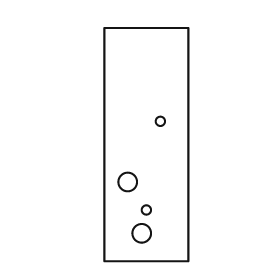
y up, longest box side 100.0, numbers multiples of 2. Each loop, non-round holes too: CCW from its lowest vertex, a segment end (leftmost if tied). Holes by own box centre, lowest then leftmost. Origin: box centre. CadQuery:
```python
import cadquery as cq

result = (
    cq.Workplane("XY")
    .moveTo(-18.0, -50.0)
    .lineTo(18.0, -50.0)
    .lineTo(18.0, 50.0)
    .lineTo(-18.0, 50.0)
    .close()
    .moveTo(-2.0, -38.0)
    .circle(4.0)
    .moveTo(0.0, -28.0)
    .circle(2.0)
    .moveTo(-8.0, -16.0)
    .circle(4.0)
    .moveTo(6.0, 10.0)
    .circle(2.0)
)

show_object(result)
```